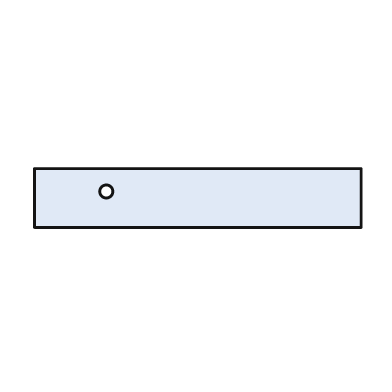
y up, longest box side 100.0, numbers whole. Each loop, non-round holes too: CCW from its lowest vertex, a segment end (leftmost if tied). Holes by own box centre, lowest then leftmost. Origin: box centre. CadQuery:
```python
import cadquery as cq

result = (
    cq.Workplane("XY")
    .moveTo(-50.0, -9.0)
    .lineTo(50.0, -9.0)
    .lineTo(50.0, 9.0)
    .lineTo(-50.0, 9.0)
    .close()
    .moveTo(-28.0, 2.0)
    .circle(2.0)
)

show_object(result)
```